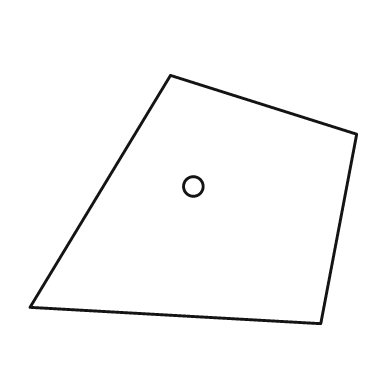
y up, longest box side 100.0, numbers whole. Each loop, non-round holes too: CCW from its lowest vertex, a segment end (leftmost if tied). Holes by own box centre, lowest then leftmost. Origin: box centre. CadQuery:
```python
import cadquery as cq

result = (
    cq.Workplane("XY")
    .moveTo(39.0, -38.0)
    .lineTo(50.0, 20.0)
    .lineTo(-7.0, 38.0)
    .lineTo(-50.0, -33.0)
    .close()
    .moveTo(0.0, 4.0)
    .circle(3.0)
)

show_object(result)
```